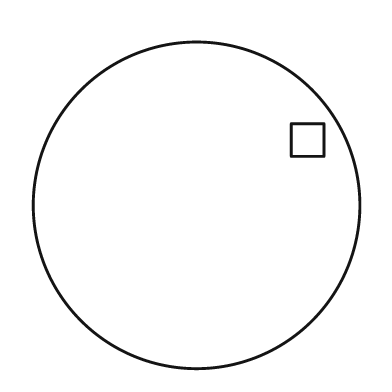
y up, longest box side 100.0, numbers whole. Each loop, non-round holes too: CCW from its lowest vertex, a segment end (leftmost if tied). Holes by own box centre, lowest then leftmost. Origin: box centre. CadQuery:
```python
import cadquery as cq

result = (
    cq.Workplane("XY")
    .moveTo(0.0, 0.0)
    .circle(50.0)
    .moveTo(29.0, 15.0)
    .lineTo(39.0, 15.0)
    .lineTo(39.0, 25.0)
    .lineTo(29.0, 25.0)
    .close()
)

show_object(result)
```